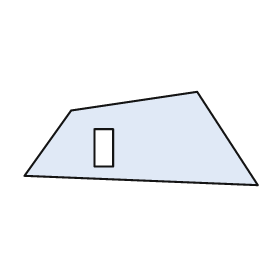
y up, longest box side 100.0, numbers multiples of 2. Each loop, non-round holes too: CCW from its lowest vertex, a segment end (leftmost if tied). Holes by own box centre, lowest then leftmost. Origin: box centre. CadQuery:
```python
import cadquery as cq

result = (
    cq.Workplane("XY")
    .moveTo(50.0, -20.0)
    .lineTo(24.0, 20.0)
    .lineTo(-30.0, 12.0)
    .lineTo(-50.0, -16.0)
    .close()
    .moveTo(-20.0, -12.0)
    .lineTo(-12.0, -12.0)
    .lineTo(-12.0, 4.0)
    .lineTo(-20.0, 4.0)
    .close()
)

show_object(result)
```